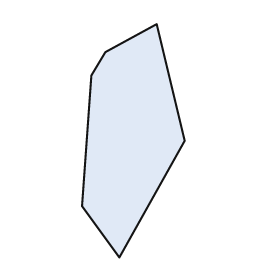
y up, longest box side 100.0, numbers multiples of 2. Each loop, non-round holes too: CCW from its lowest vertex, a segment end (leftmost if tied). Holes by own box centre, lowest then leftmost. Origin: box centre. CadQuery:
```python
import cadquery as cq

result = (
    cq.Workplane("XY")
    .moveTo(-6.0, -50.0)
    .lineTo(22.0, 0.0)
    .lineTo(10.0, 50.0)
    .lineTo(-12.0, 38.0)
    .lineTo(-18.0, 28.0)
    .lineTo(-22.0, -28.0)
    .close()
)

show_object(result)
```